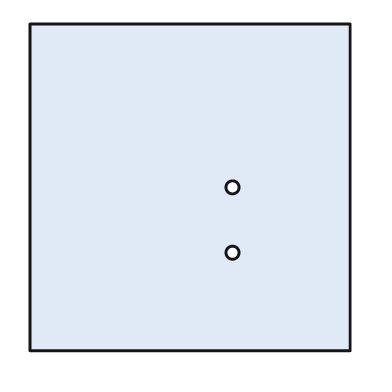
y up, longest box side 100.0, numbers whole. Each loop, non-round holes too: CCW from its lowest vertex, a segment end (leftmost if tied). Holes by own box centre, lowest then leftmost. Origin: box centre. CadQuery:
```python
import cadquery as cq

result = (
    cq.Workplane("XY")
    .moveTo(-49.0, -50.0)
    .lineTo(49.0, -50.0)
    .lineTo(49.0, 50.0)
    .lineTo(-49.0, 50.0)
    .close()
    .moveTo(13.0, -20.0)
    .circle(2.0)
    .moveTo(13.0, 0.0)
    .circle(2.0)
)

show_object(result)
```